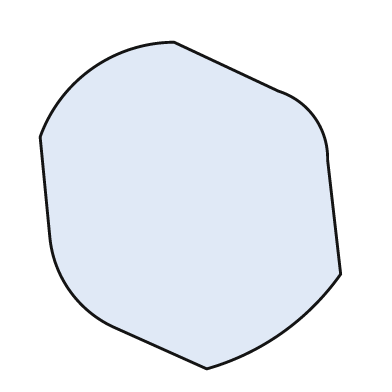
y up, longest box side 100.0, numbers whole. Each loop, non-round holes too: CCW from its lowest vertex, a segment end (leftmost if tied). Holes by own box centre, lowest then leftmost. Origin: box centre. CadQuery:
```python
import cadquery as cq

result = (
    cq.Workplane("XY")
    .moveTo(5.0, -50.0)
    .threePointArc((28.0, -39.0), (46.0, -21.0))
    .lineTo(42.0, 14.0)
    .threePointArc((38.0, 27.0), (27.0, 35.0))
    .lineTo(-5.0, 50.0)
    .threePointArc((-30.0, 42.0), (-46.0, 21.0))
    .lineTo(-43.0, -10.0)
    .threePointArc((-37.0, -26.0), (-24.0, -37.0))
    .close()
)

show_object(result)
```